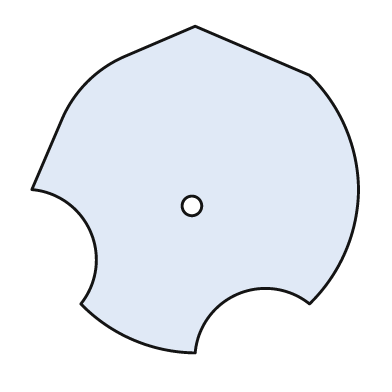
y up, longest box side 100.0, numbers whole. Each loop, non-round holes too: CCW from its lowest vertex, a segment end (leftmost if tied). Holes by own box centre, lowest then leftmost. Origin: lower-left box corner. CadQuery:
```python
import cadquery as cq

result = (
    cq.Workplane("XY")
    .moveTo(50.0, 0.0)
    .threePointArc((63.0, 18.0), (85.0, 15.0))
    .threePointArc((96.0, 31.0), (100.0, 50.0))
    .threePointArc((96.0, 69.0), (85.0, 85.0))
    .lineTo(50.0, 100.0)
    .lineTo(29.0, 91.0)
    .threePointArc((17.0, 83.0), (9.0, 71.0))
    .lineTo(0.0, 50.0)
    .threePointArc((18.0, 37.0), (15.0, 15.0))
    .threePointArc((31.0, 4.0), (50.0, 0.0))
    .close()
    .moveTo(49.0, 45.0)
    .circle(3.0)
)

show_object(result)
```